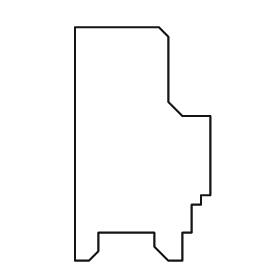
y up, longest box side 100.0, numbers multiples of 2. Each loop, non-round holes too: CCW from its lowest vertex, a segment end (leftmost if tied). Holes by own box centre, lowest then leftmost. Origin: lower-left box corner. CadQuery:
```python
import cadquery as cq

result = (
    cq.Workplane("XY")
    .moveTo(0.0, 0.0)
    .lineTo(6.0, 0.0)
    .lineTo(10.0, 4.0)
    .lineTo(10.0, 12.0)
    .lineTo(34.0, 12.0)
    .lineTo(34.0, 6.0)
    .lineTo(40.0, 0.0)
    .lineTo(46.0, 0.0)
    .lineTo(46.0, 12.0)
    .lineTo(50.0, 12.0)
    .lineTo(50.0, 24.0)
    .lineTo(54.0, 24.0)
    .lineTo(54.0, 28.0)
    .lineTo(58.0, 28.0)
    .lineTo(58.0, 62.0)
    .lineTo(46.0, 62.0)
    .lineTo(40.0, 68.0)
    .lineTo(40.0, 96.0)
    .lineTo(36.0, 100.0)
    .lineTo(0.0, 100.0)
    .close()
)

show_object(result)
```